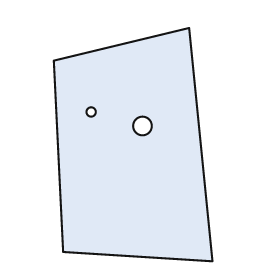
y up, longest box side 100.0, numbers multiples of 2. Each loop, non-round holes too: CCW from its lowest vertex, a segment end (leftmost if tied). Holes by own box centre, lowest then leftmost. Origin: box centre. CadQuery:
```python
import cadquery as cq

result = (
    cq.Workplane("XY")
    .moveTo(34.0, -50.0)
    .lineTo(24.0, 50.0)
    .lineTo(-34.0, 36.0)
    .lineTo(-30.0, -46.0)
    .close()
    .moveTo(4.0, 8.0)
    .circle(4.0)
    .moveTo(-18.0, 14.0)
    .circle(2.0)
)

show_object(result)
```